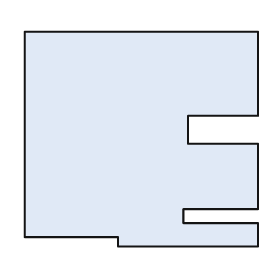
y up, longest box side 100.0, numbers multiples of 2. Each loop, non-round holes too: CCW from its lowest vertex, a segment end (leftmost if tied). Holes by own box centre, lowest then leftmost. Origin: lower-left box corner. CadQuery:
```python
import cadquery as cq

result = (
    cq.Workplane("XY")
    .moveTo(40.0, 0.0)
    .lineTo(100.0, 0.0)
    .lineTo(100.0, 10.0)
    .lineTo(68.0, 10.0)
    .lineTo(68.0, 16.0)
    .lineTo(100.0, 16.0)
    .lineTo(100.0, 44.0)
    .lineTo(70.0, 44.0)
    .lineTo(70.0, 56.0)
    .lineTo(100.0, 56.0)
    .lineTo(100.0, 92.0)
    .lineTo(0.0, 92.0)
    .lineTo(0.0, 4.0)
    .lineTo(40.0, 4.0)
    .close()
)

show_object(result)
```